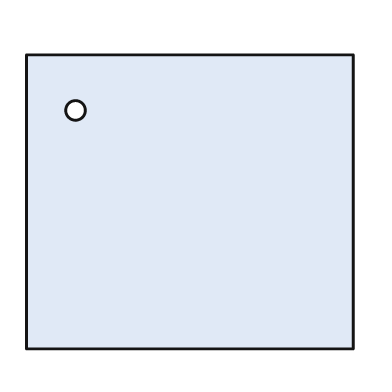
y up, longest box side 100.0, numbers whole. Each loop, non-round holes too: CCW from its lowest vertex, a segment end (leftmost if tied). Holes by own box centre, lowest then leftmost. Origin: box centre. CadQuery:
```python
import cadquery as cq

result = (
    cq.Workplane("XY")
    .moveTo(-50.0, -45.0)
    .lineTo(50.0, -45.0)
    .lineTo(50.0, 45.0)
    .lineTo(-50.0, 45.0)
    .close()
    .moveTo(-35.0, 28.0)
    .circle(3.0)
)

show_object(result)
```